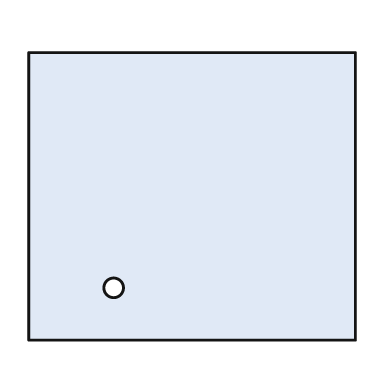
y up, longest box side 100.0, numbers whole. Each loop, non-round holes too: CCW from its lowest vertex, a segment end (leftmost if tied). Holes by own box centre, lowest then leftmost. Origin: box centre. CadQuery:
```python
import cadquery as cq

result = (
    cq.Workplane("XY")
    .moveTo(-50.0, -44.0)
    .lineTo(50.0, -44.0)
    .lineTo(50.0, 44.0)
    .lineTo(-50.0, 44.0)
    .close()
    .moveTo(-24.0, -28.0)
    .circle(3.0)
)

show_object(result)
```